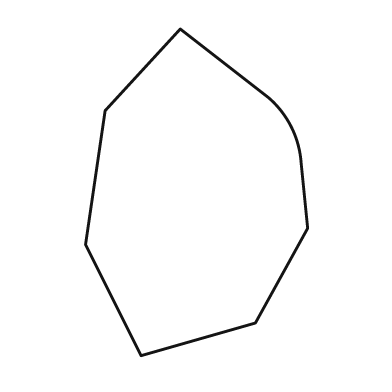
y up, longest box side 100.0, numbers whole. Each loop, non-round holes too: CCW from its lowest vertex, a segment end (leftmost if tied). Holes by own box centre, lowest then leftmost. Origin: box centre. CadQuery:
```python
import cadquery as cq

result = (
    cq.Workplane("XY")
    .moveTo(-17.0, -50.0)
    .lineTo(18.0, -40.0)
    .lineTo(34.0, -11.0)
    .lineTo(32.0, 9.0)
    .threePointArc((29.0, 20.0), (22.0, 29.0))
    .lineTo(-5.0, 50.0)
    .lineTo(-28.0, 25.0)
    .lineTo(-34.0, -16.0)
    .close()
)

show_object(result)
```